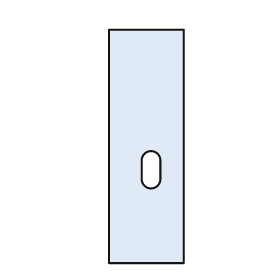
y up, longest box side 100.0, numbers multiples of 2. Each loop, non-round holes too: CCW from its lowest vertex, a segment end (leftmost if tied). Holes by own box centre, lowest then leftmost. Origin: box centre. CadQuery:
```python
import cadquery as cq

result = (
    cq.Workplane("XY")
    .moveTo(-16.0, -50.0)
    .lineTo(16.0, -50.0)
    .lineTo(16.0, 50.0)
    .lineTo(-16.0, 50.0)
    .close()
    .moveTo(-2.0, -14.0)
    .threePointArc((2.0, -18.0), (6.0, -14.0))
    .lineTo(6.0, -6.0)
    .threePointArc((2.0, -2.0), (-2.0, -6.0))
    .close()
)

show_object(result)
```